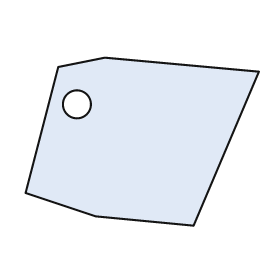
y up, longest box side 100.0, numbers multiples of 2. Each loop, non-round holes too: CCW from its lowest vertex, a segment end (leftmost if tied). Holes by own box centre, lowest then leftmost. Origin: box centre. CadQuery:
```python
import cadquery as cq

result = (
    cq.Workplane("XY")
    .moveTo(22.0, -36.0)
    .lineTo(50.0, 30.0)
    .lineTo(-16.0, 36.0)
    .lineTo(-36.0, 32.0)
    .lineTo(-50.0, -22.0)
    .lineTo(-20.0, -32.0)
    .close()
    .moveTo(-28.0, 16.0)
    .circle(6.0)
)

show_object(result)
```